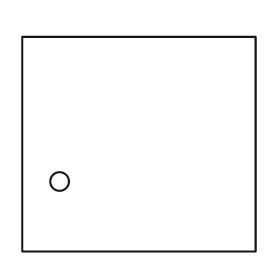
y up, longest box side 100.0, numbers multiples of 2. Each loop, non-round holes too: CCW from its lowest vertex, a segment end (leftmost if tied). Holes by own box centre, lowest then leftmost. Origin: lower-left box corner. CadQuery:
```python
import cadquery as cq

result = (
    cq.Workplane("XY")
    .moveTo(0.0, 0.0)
    .lineTo(100.0, 0.0)
    .lineTo(100.0, 92.0)
    .lineTo(0.0, 92.0)
    .close()
    .moveTo(16.0, 30.0)
    .circle(4.0)
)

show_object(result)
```